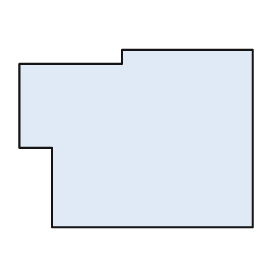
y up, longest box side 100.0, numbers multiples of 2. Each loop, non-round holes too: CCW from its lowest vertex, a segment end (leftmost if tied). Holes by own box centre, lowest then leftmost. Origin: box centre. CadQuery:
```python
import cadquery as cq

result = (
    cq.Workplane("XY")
    .moveTo(-36.0, -38.0)
    .lineTo(50.0, -38.0)
    .lineTo(50.0, 38.0)
    .lineTo(-6.0, 38.0)
    .lineTo(-6.0, 32.0)
    .lineTo(-50.0, 32.0)
    .lineTo(-50.0, -4.0)
    .lineTo(-36.0, -4.0)
    .close()
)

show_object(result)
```